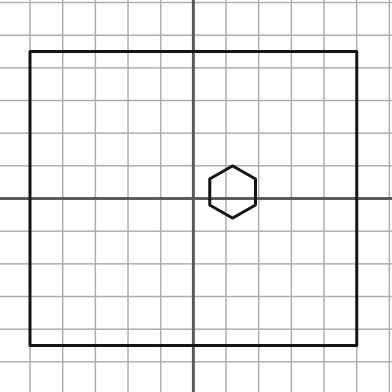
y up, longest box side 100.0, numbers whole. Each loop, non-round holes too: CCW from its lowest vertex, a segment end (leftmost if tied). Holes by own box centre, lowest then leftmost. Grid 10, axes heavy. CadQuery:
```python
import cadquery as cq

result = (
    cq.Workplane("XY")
    .moveTo(-50.0, -45.0)
    .lineTo(50.0, -45.0)
    .lineTo(50.0, 45.0)
    .lineTo(-50.0, 45.0)
    .close()
    .moveTo(12.0, -6.0)
    .lineTo(19.0, -2.0)
    .lineTo(19.0, 6.0)
    .lineTo(12.0, 10.0)
    .lineTo(5.0, 6.0)
    .lineTo(5.0, -2.0)
    .close()
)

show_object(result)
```